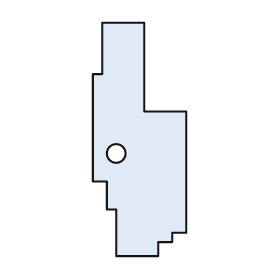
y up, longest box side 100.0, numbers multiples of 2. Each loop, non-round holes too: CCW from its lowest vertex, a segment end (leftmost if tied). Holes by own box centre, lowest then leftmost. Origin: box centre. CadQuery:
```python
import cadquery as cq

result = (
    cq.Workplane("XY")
    .moveTo(-10.0, -50.0)
    .lineTo(8.0, -50.0)
    .lineTo(8.0, -44.0)
    .lineTo(14.0, -44.0)
    .lineTo(14.0, -40.0)
    .lineTo(20.0, -40.0)
    .lineTo(20.0, 12.0)
    .lineTo(2.0, 12.0)
    .lineTo(2.0, 50.0)
    .lineTo(-16.0, 50.0)
    .lineTo(-16.0, 28.0)
    .lineTo(-20.0, 28.0)
    .lineTo(-20.0, -18.0)
    .lineTo(-14.0, -18.0)
    .lineTo(-14.0, -30.0)
    .lineTo(-10.0, -30.0)
    .close()
    .moveTo(-10.0, -6.0)
    .circle(4.0)
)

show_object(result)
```